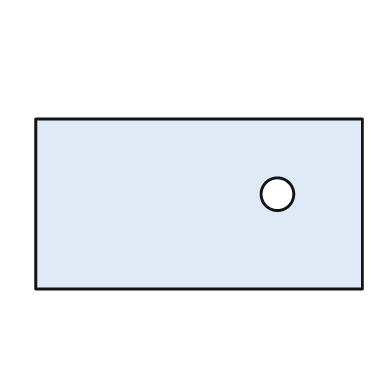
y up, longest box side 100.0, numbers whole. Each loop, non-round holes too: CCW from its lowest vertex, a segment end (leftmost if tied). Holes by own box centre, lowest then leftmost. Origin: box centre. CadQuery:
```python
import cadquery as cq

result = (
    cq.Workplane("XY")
    .moveTo(-50.0, -26.0)
    .lineTo(50.0, -26.0)
    .lineTo(50.0, 26.0)
    .lineTo(-50.0, 26.0)
    .close()
    .moveTo(24.0, 3.0)
    .circle(5.0)
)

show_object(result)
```